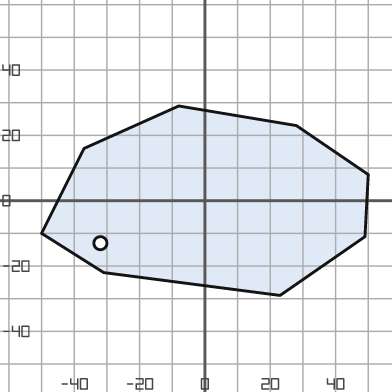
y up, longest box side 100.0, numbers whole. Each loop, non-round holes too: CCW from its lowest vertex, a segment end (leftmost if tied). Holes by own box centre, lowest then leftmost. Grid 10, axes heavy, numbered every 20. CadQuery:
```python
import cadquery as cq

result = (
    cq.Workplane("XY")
    .moveTo(23.0, -29.0)
    .lineTo(49.0, -11.0)
    .lineTo(50.0, 8.0)
    .lineTo(28.0, 23.0)
    .lineTo(-8.0, 29.0)
    .lineTo(-37.0, 16.0)
    .lineTo(-50.0, -10.0)
    .lineTo(-31.0, -22.0)
    .close()
    .moveTo(-32.0, -13.0)
    .circle(2.0)
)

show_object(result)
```